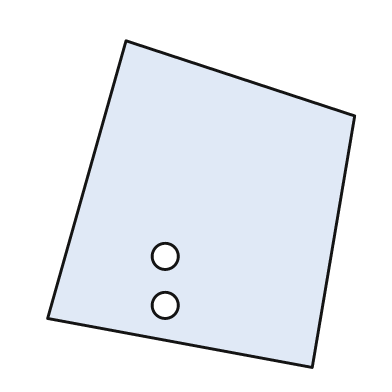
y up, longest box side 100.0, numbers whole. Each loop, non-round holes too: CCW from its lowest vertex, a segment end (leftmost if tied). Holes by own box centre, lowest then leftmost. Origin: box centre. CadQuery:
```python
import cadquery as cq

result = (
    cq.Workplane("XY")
    .moveTo(34.0, -50.0)
    .lineTo(47.0, 27.0)
    .lineTo(-23.0, 50.0)
    .lineTo(-47.0, -35.0)
    .close()
    .moveTo(-11.0, -31.0)
    .circle(4.0)
    .moveTo(-11.0, -16.0)
    .circle(4.0)
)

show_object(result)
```